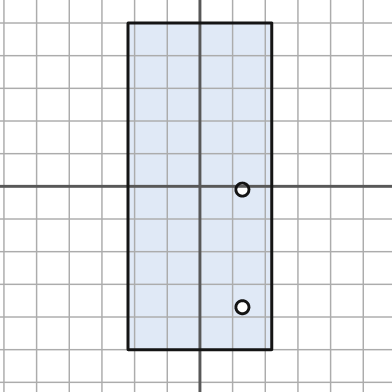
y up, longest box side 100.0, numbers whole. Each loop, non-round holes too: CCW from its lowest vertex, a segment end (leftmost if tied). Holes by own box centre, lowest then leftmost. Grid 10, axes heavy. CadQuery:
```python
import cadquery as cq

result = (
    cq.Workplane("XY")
    .moveTo(-22.0, -50.0)
    .lineTo(22.0, -50.0)
    .lineTo(22.0, 50.0)
    .lineTo(-22.0, 50.0)
    .close()
    .moveTo(13.0, -37.0)
    .circle(2.0)
    .moveTo(13.0, -1.0)
    .circle(2.0)
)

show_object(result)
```